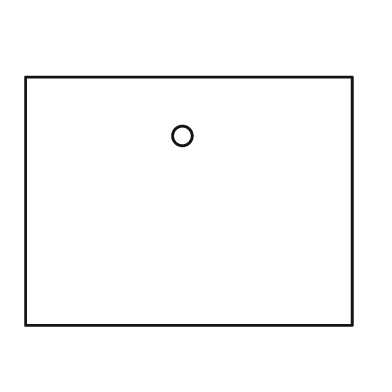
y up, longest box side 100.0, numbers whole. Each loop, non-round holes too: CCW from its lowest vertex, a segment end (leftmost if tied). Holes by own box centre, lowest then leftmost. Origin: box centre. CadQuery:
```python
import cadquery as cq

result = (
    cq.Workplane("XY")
    .moveTo(-50.0, -38.0)
    .lineTo(50.0, -38.0)
    .lineTo(50.0, 38.0)
    .lineTo(-50.0, 38.0)
    .close()
    .moveTo(-2.0, 20.0)
    .circle(3.0)
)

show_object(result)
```